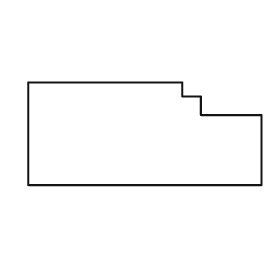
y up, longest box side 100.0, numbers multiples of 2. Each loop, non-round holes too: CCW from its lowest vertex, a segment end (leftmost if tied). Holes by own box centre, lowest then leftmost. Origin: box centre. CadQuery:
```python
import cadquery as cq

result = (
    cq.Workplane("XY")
    .moveTo(-50.0, -22.0)
    .lineTo(50.0, -22.0)
    .lineTo(50.0, 8.0)
    .lineTo(24.0, 8.0)
    .lineTo(24.0, 16.0)
    .lineTo(16.0, 16.0)
    .lineTo(16.0, 22.0)
    .lineTo(-50.0, 22.0)
    .close()
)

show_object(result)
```